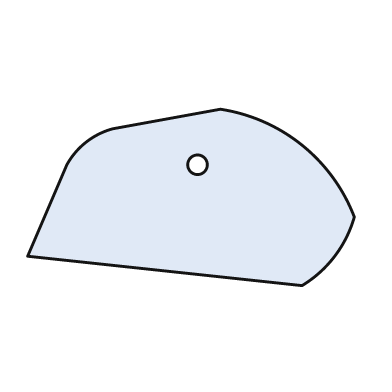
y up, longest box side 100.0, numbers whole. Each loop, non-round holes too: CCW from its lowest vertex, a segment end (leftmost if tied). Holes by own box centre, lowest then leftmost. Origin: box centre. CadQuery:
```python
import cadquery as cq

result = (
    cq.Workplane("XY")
    .moveTo(34.0, -27.0)
    .threePointArc((44.0, -18.0), (50.0, -6.0))
    .threePointArc((34.0, 16.0), (9.0, 27.0))
    .lineTo(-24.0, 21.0)
    .threePointArc((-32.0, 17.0), (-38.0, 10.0))
    .lineTo(-50.0, -18.0)
    .close()
    .moveTo(2.0, 10.0)
    .circle(3.0)
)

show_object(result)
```